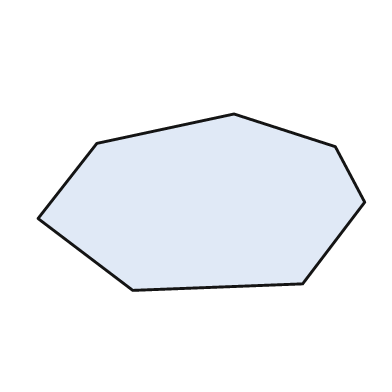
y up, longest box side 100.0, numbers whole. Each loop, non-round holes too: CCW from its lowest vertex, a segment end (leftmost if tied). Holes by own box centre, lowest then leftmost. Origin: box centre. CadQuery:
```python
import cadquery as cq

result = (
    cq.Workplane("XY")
    .moveTo(-21.0, -27.0)
    .lineTo(31.0, -25.0)
    .lineTo(50.0, 0.0)
    .lineTo(41.0, 17.0)
    .lineTo(10.0, 27.0)
    .lineTo(-32.0, 18.0)
    .lineTo(-50.0, -5.0)
    .close()
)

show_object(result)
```